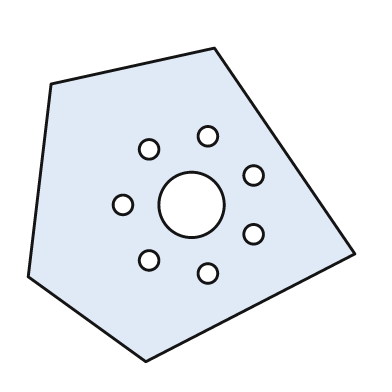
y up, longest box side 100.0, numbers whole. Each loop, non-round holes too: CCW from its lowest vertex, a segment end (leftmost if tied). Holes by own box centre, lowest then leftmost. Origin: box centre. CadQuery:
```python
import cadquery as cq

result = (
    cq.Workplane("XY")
    .moveTo(-14.0, -48.0)
    .lineTo(50.0, -15.0)
    .lineTo(7.0, 48.0)
    .lineTo(-43.0, 37.0)
    .lineTo(-50.0, -22.0)
    .close()
    .moveTo(5.0, -21.0)
    .circle(3.0)
    .moveTo(-13.0, -17.0)
    .circle(3.0)
    .moveTo(19.0, -9.0)
    .circle(3.0)
    .moveTo(-21.0, 0.0)
    .circle(3.0)
    .moveTo(0.0, 0.0)
    .circle(10.0)
    .moveTo(19.0, 9.0)
    .circle(3.0)
    .moveTo(-13.0, 17.0)
    .circle(3.0)
    .moveTo(5.0, 21.0)
    .circle(3.0)
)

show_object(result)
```